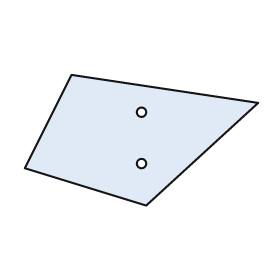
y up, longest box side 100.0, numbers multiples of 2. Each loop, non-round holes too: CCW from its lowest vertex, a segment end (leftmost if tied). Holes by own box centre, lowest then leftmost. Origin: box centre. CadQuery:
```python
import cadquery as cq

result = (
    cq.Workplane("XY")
    .moveTo(2.0, -28.0)
    .lineTo(50.0, 16.0)
    .lineTo(-30.0, 28.0)
    .lineTo(-50.0, -12.0)
    .close()
    .moveTo(0.0, -10.0)
    .circle(2.0)
    .moveTo(0.0, 12.0)
    .circle(2.0)
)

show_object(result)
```